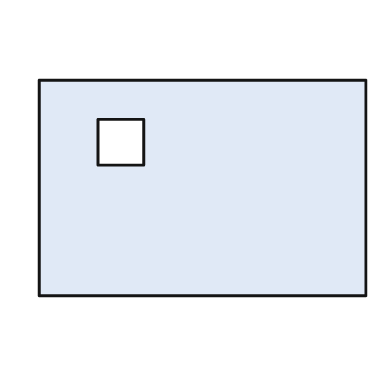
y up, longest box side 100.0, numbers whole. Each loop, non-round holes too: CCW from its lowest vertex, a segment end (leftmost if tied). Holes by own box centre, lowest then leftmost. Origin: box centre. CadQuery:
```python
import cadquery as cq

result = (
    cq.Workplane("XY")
    .moveTo(-50.0, -33.0)
    .lineTo(50.0, -33.0)
    .lineTo(50.0, 33.0)
    .lineTo(-50.0, 33.0)
    .close()
    .moveTo(-32.0, 7.0)
    .lineTo(-18.0, 7.0)
    .lineTo(-18.0, 21.0)
    .lineTo(-32.0, 21.0)
    .close()
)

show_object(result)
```